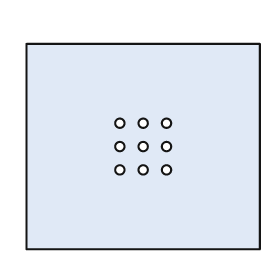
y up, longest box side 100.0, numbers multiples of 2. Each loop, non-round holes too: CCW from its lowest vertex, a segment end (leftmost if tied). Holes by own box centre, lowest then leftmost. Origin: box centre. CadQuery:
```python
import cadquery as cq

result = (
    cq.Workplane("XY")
    .moveTo(-50.0, -44.0)
    .lineTo(50.0, -44.0)
    .lineTo(50.0, 44.0)
    .lineTo(-50.0, 44.0)
    .close()
    .moveTo(-10.0, -10.0)
    .circle(2.0)
    .moveTo(0.0, -10.0)
    .circle(2.0)
    .moveTo(10.0, -10.0)
    .circle(2.0)
    .moveTo(-10.0, 0.0)
    .circle(2.0)
    .moveTo(0.0, 0.0)
    .circle(2.0)
    .moveTo(10.0, 0.0)
    .circle(2.0)
    .moveTo(-10.0, 10.0)
    .circle(2.0)
    .moveTo(0.0, 10.0)
    .circle(2.0)
    .moveTo(10.0, 10.0)
    .circle(2.0)
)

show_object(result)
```